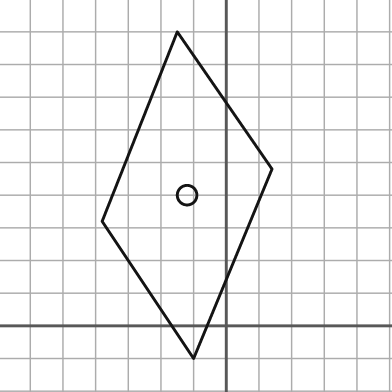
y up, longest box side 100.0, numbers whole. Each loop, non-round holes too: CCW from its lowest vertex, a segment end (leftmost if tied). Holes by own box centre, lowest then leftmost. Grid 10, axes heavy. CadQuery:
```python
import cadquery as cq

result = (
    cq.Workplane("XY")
    .moveTo(-10.0, -10.0)
    .lineTo(14.0, 48.0)
    .lineTo(-15.0, 90.0)
    .lineTo(-38.0, 32.0)
    .close()
    .moveTo(-12.0, 40.0)
    .circle(3.0)
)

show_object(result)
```